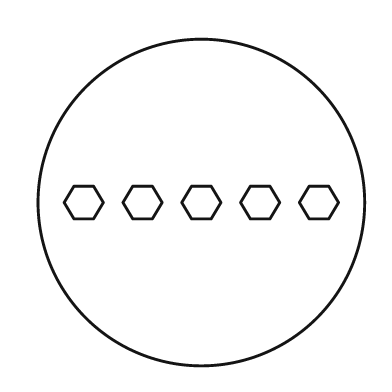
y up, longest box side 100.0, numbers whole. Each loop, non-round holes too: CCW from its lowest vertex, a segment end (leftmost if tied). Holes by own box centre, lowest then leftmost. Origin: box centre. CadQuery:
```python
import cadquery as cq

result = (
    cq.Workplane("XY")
    .moveTo(0.0, 0.0)
    .circle(50.0)
    .moveTo(-39.0, -5.0)
    .lineTo(-33.0, -5.0)
    .lineTo(-30.0, 0.0)
    .lineTo(-33.0, 5.0)
    .lineTo(-39.0, 5.0)
    .lineTo(-42.0, 0.0)
    .close()
    .moveTo(-21.0, -5.0)
    .lineTo(-15.0, -5.0)
    .lineTo(-12.0, 0.0)
    .lineTo(-15.0, 5.0)
    .lineTo(-21.0, 5.0)
    .lineTo(-24.0, 0.0)
    .close()
    .moveTo(-3.0, -5.0)
    .lineTo(3.0, -5.0)
    .lineTo(6.0, 0.0)
    .lineTo(3.0, 5.0)
    .lineTo(-3.0, 5.0)
    .lineTo(-6.0, 0.0)
    .close()
    .moveTo(15.0, -5.0)
    .lineTo(21.0, -5.0)
    .lineTo(24.0, 0.0)
    .lineTo(21.0, 5.0)
    .lineTo(15.0, 5.0)
    .lineTo(12.0, 0.0)
    .close()
    .moveTo(33.0, -5.0)
    .lineTo(39.0, -5.0)
    .lineTo(42.0, 0.0)
    .lineTo(39.0, 5.0)
    .lineTo(33.0, 5.0)
    .lineTo(30.0, 0.0)
    .close()
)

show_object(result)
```